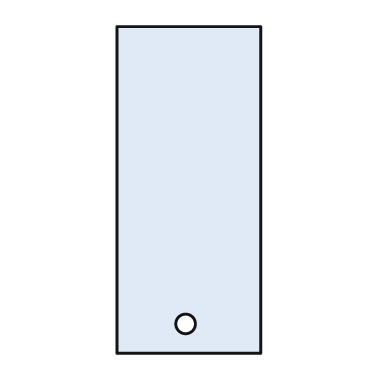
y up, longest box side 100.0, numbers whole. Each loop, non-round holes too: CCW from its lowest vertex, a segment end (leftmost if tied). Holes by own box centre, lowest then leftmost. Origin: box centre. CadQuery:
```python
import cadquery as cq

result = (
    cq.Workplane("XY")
    .moveTo(-22.0, -50.0)
    .lineTo(22.0, -50.0)
    .lineTo(22.0, 50.0)
    .lineTo(-22.0, 50.0)
    .close()
    .moveTo(-1.0, -41.0)
    .circle(3.0)
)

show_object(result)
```